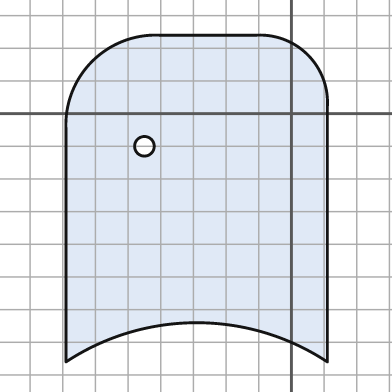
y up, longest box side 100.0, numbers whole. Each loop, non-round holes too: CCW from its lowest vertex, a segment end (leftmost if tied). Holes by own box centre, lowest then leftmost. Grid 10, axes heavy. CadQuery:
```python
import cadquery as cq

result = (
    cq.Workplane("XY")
    .moveTo(-69.0, -76.0)
    .threePointArc((-29.0, -64.0), (11.0, -76.0))
    .lineTo(11.0, 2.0)
    .threePointArc((5.0, 18.0), (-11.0, 24.0))
    .lineTo(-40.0, 24.0)
    .threePointArc((-61.0, 16.0), (-69.0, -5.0))
    .close()
    .moveTo(-45.0, -10.0)
    .circle(3.0)
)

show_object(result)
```